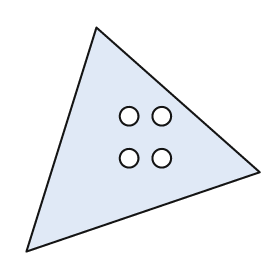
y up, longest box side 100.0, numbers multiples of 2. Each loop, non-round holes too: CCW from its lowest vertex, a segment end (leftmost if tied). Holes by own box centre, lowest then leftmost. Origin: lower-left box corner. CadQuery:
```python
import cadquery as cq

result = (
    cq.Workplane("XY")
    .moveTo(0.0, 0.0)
    .lineTo(100.0, 34.0)
    .lineTo(30.0, 96.0)
    .close()
    .moveTo(44.0, 40.0)
    .circle(4.0)
    .moveTo(58.0, 40.0)
    .circle(4.0)
    .moveTo(44.0, 58.0)
    .circle(4.0)
    .moveTo(58.0, 58.0)
    .circle(4.0)
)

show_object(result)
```